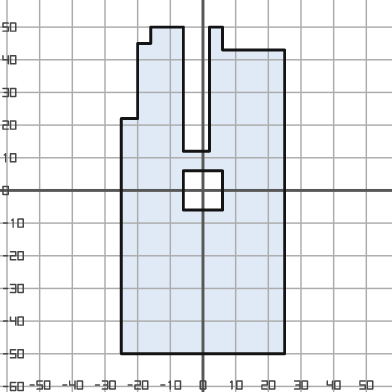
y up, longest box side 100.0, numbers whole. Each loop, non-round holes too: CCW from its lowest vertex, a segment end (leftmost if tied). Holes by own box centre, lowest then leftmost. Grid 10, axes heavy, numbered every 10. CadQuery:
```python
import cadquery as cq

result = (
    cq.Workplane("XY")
    .moveTo(-25.0, -50.0)
    .lineTo(25.0, -50.0)
    .lineTo(25.0, 43.0)
    .lineTo(6.0, 43.0)
    .lineTo(6.0, 50.0)
    .lineTo(2.0, 50.0)
    .lineTo(2.0, 12.0)
    .lineTo(-6.0, 12.0)
    .lineTo(-6.0, 50.0)
    .lineTo(-16.0, 50.0)
    .lineTo(-16.0, 45.0)
    .lineTo(-20.0, 45.0)
    .lineTo(-20.0, 22.0)
    .lineTo(-25.0, 22.0)
    .close()
    .moveTo(-6.0, -6.0)
    .lineTo(6.0, -6.0)
    .lineTo(6.0, 6.0)
    .lineTo(-6.0, 6.0)
    .close()
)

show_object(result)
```